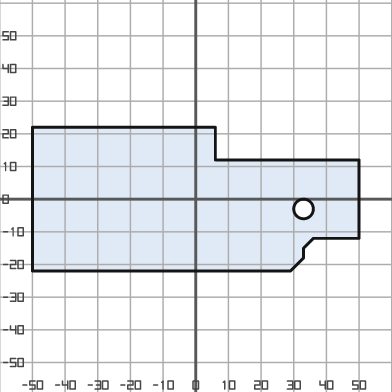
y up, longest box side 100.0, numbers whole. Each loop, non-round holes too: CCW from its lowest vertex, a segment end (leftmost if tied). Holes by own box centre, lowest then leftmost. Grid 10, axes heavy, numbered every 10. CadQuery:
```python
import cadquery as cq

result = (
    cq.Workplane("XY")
    .moveTo(-50.0, -22.0)
    .lineTo(29.0, -22.0)
    .lineTo(33.0, -18.0)
    .lineTo(33.0, -15.0)
    .lineTo(36.0, -12.0)
    .lineTo(50.0, -12.0)
    .lineTo(50.0, 12.0)
    .lineTo(6.0, 12.0)
    .lineTo(6.0, 22.0)
    .lineTo(-50.0, 22.0)
    .close()
    .moveTo(33.0, -3.0)
    .circle(3.0)
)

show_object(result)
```